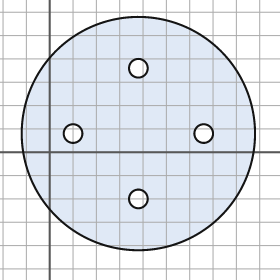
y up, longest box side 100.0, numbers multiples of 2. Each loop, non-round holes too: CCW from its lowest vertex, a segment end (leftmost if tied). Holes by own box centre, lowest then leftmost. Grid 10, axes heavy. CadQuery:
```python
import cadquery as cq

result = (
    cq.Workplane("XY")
    .moveTo(38.0, 8.0)
    .circle(50.0)
    .moveTo(38.0, -20.0)
    .circle(4.0)
    .moveTo(10.0, 8.0)
    .circle(4.0)
    .moveTo(66.0, 8.0)
    .circle(4.0)
    .moveTo(38.0, 36.0)
    .circle(4.0)
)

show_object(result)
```